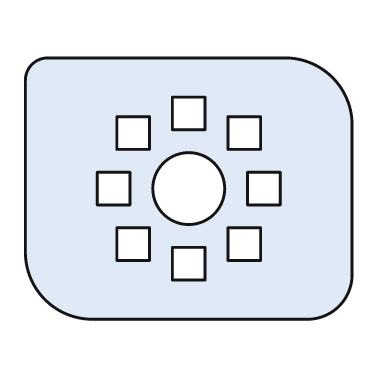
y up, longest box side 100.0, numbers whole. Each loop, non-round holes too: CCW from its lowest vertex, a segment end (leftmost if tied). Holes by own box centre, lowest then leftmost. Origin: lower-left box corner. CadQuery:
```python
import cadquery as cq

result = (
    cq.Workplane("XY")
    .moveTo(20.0, 0.0)
    .lineTo(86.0, 0.0)
    .threePointArc((96.0, 4.0), (100.0, 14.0))
    .lineTo(100.0, 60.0)
    .threePointArc((94.0, 74.0), (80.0, 80.0))
    .lineTo(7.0, 80.0)
    .threePointArc((2.0, 78.0), (0.0, 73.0))
    .lineTo(0.0, 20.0)
    .threePointArc((6.0, 6.0), (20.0, 0.0))
    .close()
    .moveTo(45.0, 12.0)
    .lineTo(55.0, 12.0)
    .lineTo(55.0, 22.0)
    .lineTo(45.0, 22.0)
    .close()
    .moveTo(28.0, 18.0)
    .lineTo(38.0, 18.0)
    .lineTo(38.0, 28.0)
    .lineTo(28.0, 28.0)
    .close()
    .moveTo(62.0, 18.0)
    .lineTo(72.0, 18.0)
    .lineTo(72.0, 28.0)
    .lineTo(62.0, 28.0)
    .close()
    .moveTo(22.0, 35.0)
    .lineTo(32.0, 35.0)
    .lineTo(32.0, 45.0)
    .lineTo(22.0, 45.0)
    .close()
    .moveTo(50.0, 40.0)
    .circle(11.0)
    .moveTo(68.0, 35.0)
    .lineTo(78.0, 35.0)
    .lineTo(78.0, 45.0)
    .lineTo(68.0, 45.0)
    .close()
    .moveTo(28.0, 52.0)
    .lineTo(38.0, 52.0)
    .lineTo(38.0, 62.0)
    .lineTo(28.0, 62.0)
    .close()
    .moveTo(62.0, 52.0)
    .lineTo(72.0, 52.0)
    .lineTo(72.0, 62.0)
    .lineTo(62.0, 62.0)
    .close()
    .moveTo(45.0, 58.0)
    .lineTo(55.0, 58.0)
    .lineTo(55.0, 68.0)
    .lineTo(45.0, 68.0)
    .close()
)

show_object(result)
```